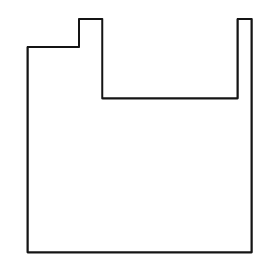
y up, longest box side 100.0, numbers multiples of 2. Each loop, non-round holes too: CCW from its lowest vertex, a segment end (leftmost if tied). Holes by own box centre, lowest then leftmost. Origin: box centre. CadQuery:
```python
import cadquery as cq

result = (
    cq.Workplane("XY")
    .moveTo(-48.0, -50.0)
    .lineTo(48.0, -50.0)
    .lineTo(48.0, 50.0)
    .lineTo(42.0, 50.0)
    .lineTo(42.0, 16.0)
    .lineTo(-16.0, 16.0)
    .lineTo(-16.0, 50.0)
    .lineTo(-26.0, 50.0)
    .lineTo(-26.0, 38.0)
    .lineTo(-48.0, 38.0)
    .close()
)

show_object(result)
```